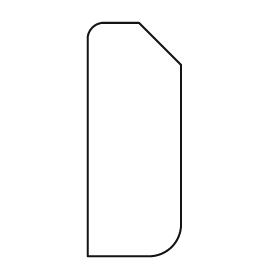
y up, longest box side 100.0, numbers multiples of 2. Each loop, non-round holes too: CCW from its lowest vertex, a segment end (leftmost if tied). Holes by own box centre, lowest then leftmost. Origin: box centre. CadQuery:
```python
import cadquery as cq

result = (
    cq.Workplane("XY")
    .moveTo(-20.0, -50.0)
    .lineTo(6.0, -50.0)
    .threePointArc((16.0, -46.0), (20.0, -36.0))
    .lineTo(20.0, 32.0)
    .lineTo(2.0, 50.0)
    .lineTo(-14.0, 50.0)
    .threePointArc((-18.0, 48.0), (-20.0, 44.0))
    .close()
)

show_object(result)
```